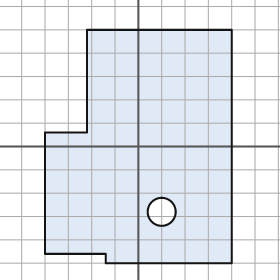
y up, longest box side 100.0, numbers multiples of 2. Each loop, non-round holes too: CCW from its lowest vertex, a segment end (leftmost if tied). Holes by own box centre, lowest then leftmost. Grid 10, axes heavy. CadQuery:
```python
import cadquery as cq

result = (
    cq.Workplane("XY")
    .moveTo(-14.0, -50.0)
    .lineTo(40.0, -50.0)
    .lineTo(40.0, 50.0)
    .lineTo(-22.0, 50.0)
    .lineTo(-22.0, 6.0)
    .lineTo(-40.0, 6.0)
    .lineTo(-40.0, -46.0)
    .lineTo(-14.0, -46.0)
    .close()
    .moveTo(10.0, -28.0)
    .circle(6.0)
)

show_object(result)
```